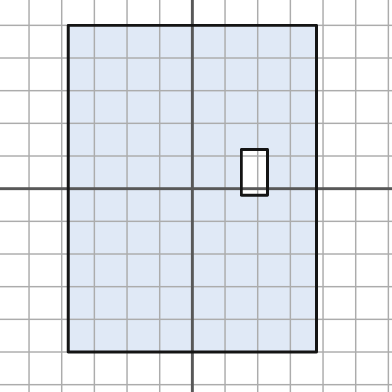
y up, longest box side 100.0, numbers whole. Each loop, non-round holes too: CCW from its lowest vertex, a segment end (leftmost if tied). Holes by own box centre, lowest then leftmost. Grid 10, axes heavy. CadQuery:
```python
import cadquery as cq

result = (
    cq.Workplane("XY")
    .moveTo(-38.0, -50.0)
    .lineTo(38.0, -50.0)
    .lineTo(38.0, 50.0)
    .lineTo(-38.0, 50.0)
    .close()
    .moveTo(15.0, -2.0)
    .lineTo(23.0, -2.0)
    .lineTo(23.0, 12.0)
    .lineTo(15.0, 12.0)
    .close()
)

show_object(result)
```